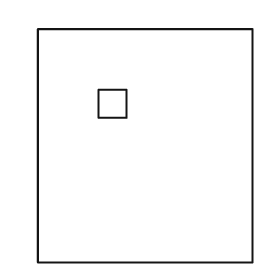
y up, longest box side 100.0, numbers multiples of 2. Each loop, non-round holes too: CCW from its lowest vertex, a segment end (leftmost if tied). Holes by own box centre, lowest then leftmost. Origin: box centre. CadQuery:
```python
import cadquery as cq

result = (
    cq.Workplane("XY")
    .moveTo(-46.0, -50.0)
    .lineTo(46.0, -50.0)
    .lineTo(46.0, 50.0)
    .lineTo(-46.0, 50.0)
    .close()
    .moveTo(-20.0, 12.0)
    .lineTo(-8.0, 12.0)
    .lineTo(-8.0, 24.0)
    .lineTo(-20.0, 24.0)
    .close()
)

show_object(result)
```